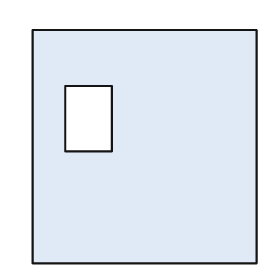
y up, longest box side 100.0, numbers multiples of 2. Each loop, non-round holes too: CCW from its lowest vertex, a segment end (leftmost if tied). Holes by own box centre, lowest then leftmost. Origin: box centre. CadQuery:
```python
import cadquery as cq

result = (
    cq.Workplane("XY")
    .moveTo(-48.0, -50.0)
    .lineTo(48.0, -50.0)
    .lineTo(48.0, 50.0)
    .lineTo(-48.0, 50.0)
    .close()
    .moveTo(-34.0, -2.0)
    .lineTo(-14.0, -2.0)
    .lineTo(-14.0, 26.0)
    .lineTo(-34.0, 26.0)
    .close()
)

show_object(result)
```